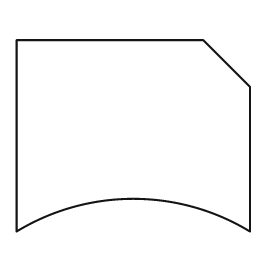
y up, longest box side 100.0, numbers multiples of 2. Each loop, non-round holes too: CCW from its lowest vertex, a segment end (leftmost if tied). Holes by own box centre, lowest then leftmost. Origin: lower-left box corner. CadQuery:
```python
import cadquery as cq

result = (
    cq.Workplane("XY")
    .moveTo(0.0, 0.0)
    .threePointArc((50.0, 14.0), (100.0, 0.0))
    .lineTo(100.0, 62.0)
    .lineTo(80.0, 82.0)
    .lineTo(0.0, 82.0)
    .close()
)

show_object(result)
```